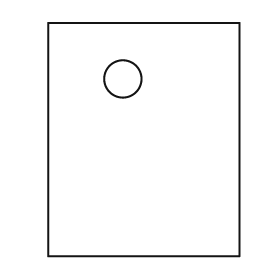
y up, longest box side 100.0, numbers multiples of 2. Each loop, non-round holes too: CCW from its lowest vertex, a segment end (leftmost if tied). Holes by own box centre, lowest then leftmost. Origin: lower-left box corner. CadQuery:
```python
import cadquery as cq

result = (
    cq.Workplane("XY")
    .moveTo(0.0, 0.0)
    .lineTo(82.0, 0.0)
    .lineTo(82.0, 100.0)
    .lineTo(0.0, 100.0)
    .close()
    .moveTo(32.0, 76.0)
    .circle(8.0)
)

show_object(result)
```